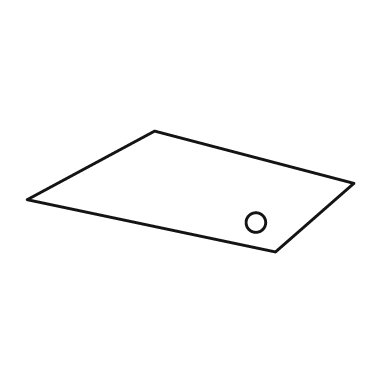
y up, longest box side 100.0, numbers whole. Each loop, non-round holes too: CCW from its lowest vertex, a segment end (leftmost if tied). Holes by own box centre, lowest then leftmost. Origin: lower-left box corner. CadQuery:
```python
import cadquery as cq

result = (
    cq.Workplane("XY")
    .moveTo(76.0, 0.0)
    .lineTo(100.0, 21.0)
    .lineTo(39.0, 37.0)
    .lineTo(0.0, 16.0)
    .close()
    .moveTo(70.0, 9.0)
    .circle(3.0)
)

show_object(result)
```